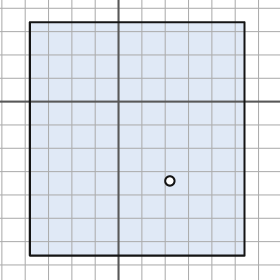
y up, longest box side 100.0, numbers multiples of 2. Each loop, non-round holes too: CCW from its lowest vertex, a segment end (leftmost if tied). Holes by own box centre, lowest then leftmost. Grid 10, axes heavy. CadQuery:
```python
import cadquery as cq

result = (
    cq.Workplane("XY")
    .moveTo(-38.0, -66.0)
    .lineTo(54.0, -66.0)
    .lineTo(54.0, 34.0)
    .lineTo(-38.0, 34.0)
    .close()
    .moveTo(22.0, -34.0)
    .circle(2.0)
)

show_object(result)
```